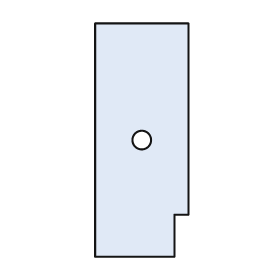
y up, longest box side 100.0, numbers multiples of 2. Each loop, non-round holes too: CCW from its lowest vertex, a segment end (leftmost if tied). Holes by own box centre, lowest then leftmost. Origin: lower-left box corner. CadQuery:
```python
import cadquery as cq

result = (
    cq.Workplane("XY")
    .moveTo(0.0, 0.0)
    .lineTo(34.0, 0.0)
    .lineTo(34.0, 18.0)
    .lineTo(40.0, 18.0)
    .lineTo(40.0, 100.0)
    .lineTo(0.0, 100.0)
    .close()
    .moveTo(20.0, 50.0)
    .circle(4.0)
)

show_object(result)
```